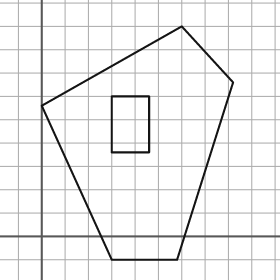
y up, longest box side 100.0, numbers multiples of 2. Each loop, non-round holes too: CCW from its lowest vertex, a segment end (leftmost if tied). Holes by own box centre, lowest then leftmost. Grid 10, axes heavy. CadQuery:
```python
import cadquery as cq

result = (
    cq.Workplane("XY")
    .moveTo(30.0, -10.0)
    .lineTo(58.0, -10.0)
    .lineTo(82.0, 66.0)
    .lineTo(60.0, 90.0)
    .lineTo(0.0, 56.0)
    .close()
    .moveTo(30.0, 36.0)
    .lineTo(46.0, 36.0)
    .lineTo(46.0, 60.0)
    .lineTo(30.0, 60.0)
    .close()
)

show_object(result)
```